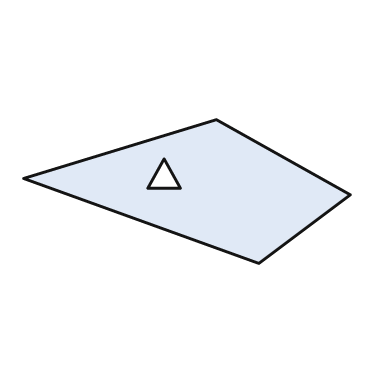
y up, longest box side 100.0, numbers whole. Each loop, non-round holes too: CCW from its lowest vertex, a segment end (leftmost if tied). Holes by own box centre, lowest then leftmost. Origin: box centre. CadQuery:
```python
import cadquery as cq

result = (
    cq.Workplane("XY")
    .moveTo(22.0, -22.0)
    .lineTo(50.0, -1.0)
    .lineTo(9.0, 22.0)
    .lineTo(-50.0, 4.0)
    .close()
    .moveTo(-12.0, 1.0)
    .lineTo(-2.0, 1.0)
    .lineTo(-7.0, 10.0)
    .close()
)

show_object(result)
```